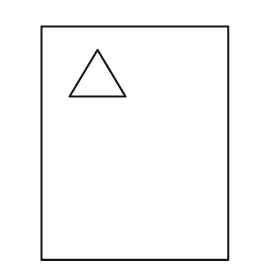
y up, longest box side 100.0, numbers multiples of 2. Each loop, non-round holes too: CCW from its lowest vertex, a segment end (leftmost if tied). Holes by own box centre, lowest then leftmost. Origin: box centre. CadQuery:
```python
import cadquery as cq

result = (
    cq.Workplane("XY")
    .moveTo(-40.0, -50.0)
    .lineTo(40.0, -50.0)
    .lineTo(40.0, 50.0)
    .lineTo(-40.0, 50.0)
    .close()
    .moveTo(-28.0, 20.0)
    .lineTo(-4.0, 20.0)
    .lineTo(-16.0, 40.0)
    .close()
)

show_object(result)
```